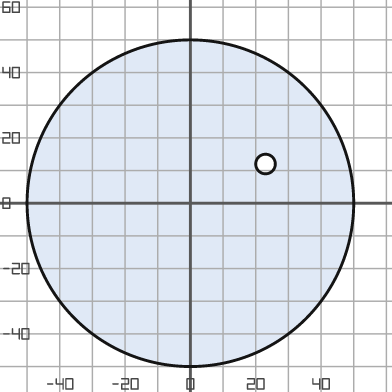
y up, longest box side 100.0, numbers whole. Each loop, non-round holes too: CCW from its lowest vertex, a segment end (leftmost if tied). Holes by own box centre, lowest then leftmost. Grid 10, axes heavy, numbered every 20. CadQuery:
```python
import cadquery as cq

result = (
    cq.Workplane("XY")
    .moveTo(0.0, 0.0)
    .circle(50.0)
    .moveTo(23.0, 12.0)
    .circle(3.0)
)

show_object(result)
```